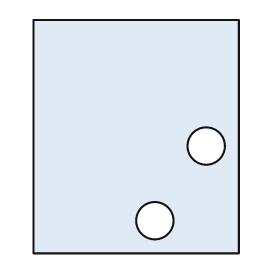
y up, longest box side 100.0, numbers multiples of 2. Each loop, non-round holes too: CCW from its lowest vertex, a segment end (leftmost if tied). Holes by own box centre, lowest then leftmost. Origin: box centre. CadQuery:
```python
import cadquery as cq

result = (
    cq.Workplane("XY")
    .moveTo(-44.0, -50.0)
    .lineTo(44.0, -50.0)
    .lineTo(44.0, 50.0)
    .lineTo(-44.0, 50.0)
    .close()
    .moveTo(8.0, -36.0)
    .circle(8.0)
    .moveTo(30.0, -4.0)
    .circle(8.0)
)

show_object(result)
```